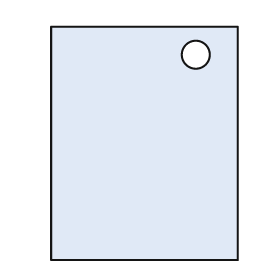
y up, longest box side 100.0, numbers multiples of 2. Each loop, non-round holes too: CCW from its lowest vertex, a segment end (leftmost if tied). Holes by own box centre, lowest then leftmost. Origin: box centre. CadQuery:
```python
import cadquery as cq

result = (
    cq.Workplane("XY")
    .moveTo(-40.0, -50.0)
    .lineTo(40.0, -50.0)
    .lineTo(40.0, 50.0)
    .lineTo(-40.0, 50.0)
    .close()
    .moveTo(22.0, 38.0)
    .circle(6.0)
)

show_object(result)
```